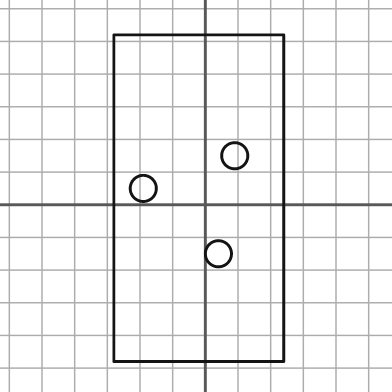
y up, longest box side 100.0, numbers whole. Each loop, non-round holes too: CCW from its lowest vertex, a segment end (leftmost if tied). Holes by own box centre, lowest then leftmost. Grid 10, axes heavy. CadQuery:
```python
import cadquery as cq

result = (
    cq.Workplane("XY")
    .moveTo(-28.0, -48.0)
    .lineTo(24.0, -48.0)
    .lineTo(24.0, 52.0)
    .lineTo(-28.0, 52.0)
    .close()
    .moveTo(4.0, -15.0)
    .circle(4.0)
    .moveTo(-19.0, 5.0)
    .circle(4.0)
    .moveTo(9.0, 15.0)
    .circle(4.0)
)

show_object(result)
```